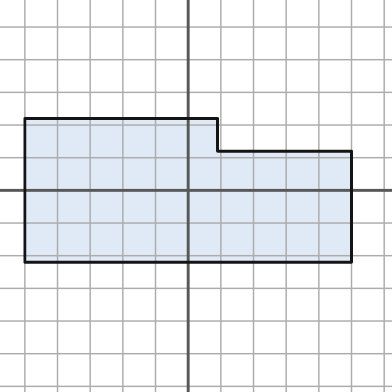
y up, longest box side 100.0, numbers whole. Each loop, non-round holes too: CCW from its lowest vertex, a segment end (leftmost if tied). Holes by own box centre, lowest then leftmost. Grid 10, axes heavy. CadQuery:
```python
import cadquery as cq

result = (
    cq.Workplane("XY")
    .moveTo(-50.0, -22.0)
    .lineTo(50.0, -22.0)
    .lineTo(50.0, 12.0)
    .lineTo(9.0, 12.0)
    .lineTo(9.0, 22.0)
    .lineTo(-50.0, 22.0)
    .close()
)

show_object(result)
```